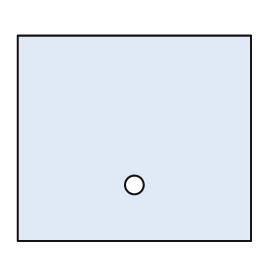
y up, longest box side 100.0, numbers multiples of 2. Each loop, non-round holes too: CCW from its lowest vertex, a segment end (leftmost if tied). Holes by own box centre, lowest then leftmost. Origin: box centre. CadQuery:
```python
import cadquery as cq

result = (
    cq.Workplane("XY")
    .moveTo(-50.0, -44.0)
    .lineTo(50.0, -44.0)
    .lineTo(50.0, 44.0)
    .lineTo(-50.0, 44.0)
    .close()
    .moveTo(0.0, -20.0)
    .circle(4.0)
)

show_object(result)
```